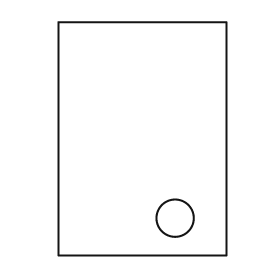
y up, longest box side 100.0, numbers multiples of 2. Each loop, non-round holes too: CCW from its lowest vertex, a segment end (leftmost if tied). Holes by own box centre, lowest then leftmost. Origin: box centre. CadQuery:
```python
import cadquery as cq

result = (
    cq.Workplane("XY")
    .moveTo(-36.0, -50.0)
    .lineTo(36.0, -50.0)
    .lineTo(36.0, 50.0)
    .lineTo(-36.0, 50.0)
    .close()
    .moveTo(14.0, -34.0)
    .circle(8.0)
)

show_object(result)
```